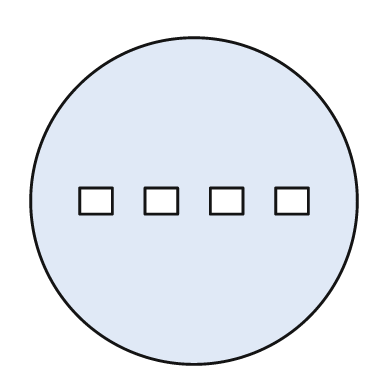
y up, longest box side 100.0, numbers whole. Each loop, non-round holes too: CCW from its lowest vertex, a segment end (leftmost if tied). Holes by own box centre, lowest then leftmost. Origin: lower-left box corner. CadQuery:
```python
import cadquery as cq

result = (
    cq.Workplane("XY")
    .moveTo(50.0, 50.0)
    .circle(50.0)
    .moveTo(15.0, 46.0)
    .lineTo(25.0, 46.0)
    .lineTo(25.0, 54.0)
    .lineTo(15.0, 54.0)
    .close()
    .moveTo(35.0, 46.0)
    .lineTo(45.0, 46.0)
    .lineTo(45.0, 54.0)
    .lineTo(35.0, 54.0)
    .close()
    .moveTo(55.0, 46.0)
    .lineTo(65.0, 46.0)
    .lineTo(65.0, 54.0)
    .lineTo(55.0, 54.0)
    .close()
    .moveTo(75.0, 46.0)
    .lineTo(85.0, 46.0)
    .lineTo(85.0, 54.0)
    .lineTo(75.0, 54.0)
    .close()
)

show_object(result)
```